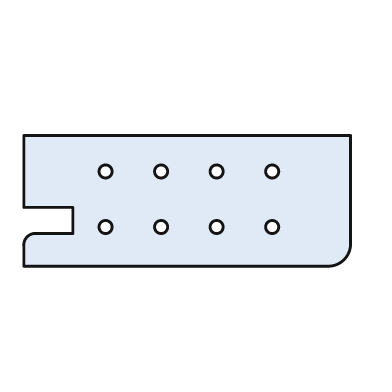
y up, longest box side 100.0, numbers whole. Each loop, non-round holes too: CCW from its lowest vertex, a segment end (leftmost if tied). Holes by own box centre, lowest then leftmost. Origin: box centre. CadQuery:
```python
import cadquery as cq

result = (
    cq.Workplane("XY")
    .moveTo(-50.0, -20.0)
    .lineTo(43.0, -20.0)
    .threePointArc((48.0, -18.0), (50.0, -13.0))
    .lineTo(50.0, 20.0)
    .lineTo(-50.0, 20.0)
    .lineTo(-50.0, -2.0)
    .lineTo(-35.0, -2.0)
    .lineTo(-35.0, -10.0)
    .lineTo(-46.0, -10.0)
    .threePointArc((-49.0, -11.0), (-50.0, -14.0))
    .close()
    .moveTo(-25.0, -8.0)
    .circle(2.0)
    .moveTo(-8.0, -8.0)
    .circle(2.0)
    .moveTo(9.0, -8.0)
    .circle(2.0)
    .moveTo(26.0, -8.0)
    .circle(2.0)
    .moveTo(-25.0, 9.0)
    .circle(2.0)
    .moveTo(-8.0, 9.0)
    .circle(2.0)
    .moveTo(9.0, 9.0)
    .circle(2.0)
    .moveTo(26.0, 9.0)
    .circle(2.0)
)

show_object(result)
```